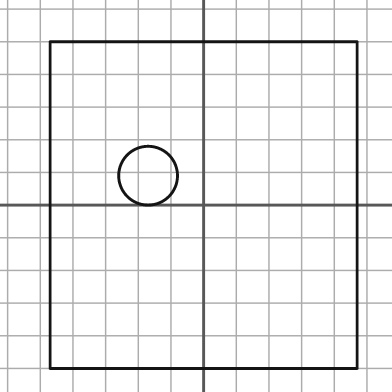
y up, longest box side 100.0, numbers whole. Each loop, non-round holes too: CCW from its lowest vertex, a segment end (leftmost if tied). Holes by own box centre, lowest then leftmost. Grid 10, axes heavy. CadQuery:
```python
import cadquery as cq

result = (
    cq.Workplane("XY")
    .moveTo(-47.0, -50.0)
    .lineTo(47.0, -50.0)
    .lineTo(47.0, 50.0)
    .lineTo(-47.0, 50.0)
    .close()
    .moveTo(-17.0, 9.0)
    .circle(9.0)
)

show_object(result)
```